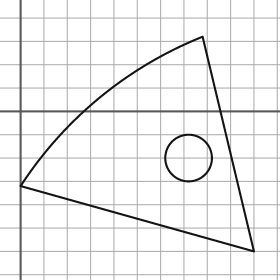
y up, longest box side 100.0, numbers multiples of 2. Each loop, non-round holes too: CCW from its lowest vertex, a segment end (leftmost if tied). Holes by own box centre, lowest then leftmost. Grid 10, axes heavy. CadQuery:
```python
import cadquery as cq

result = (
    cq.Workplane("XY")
    .moveTo(100.0, -60.0)
    .lineTo(78.0, 32.0)
    .threePointArc((34.0, 6.0), (0.0, -32.0))
    .close()
    .moveTo(72.0, -20.0)
    .circle(10.0)
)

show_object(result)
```